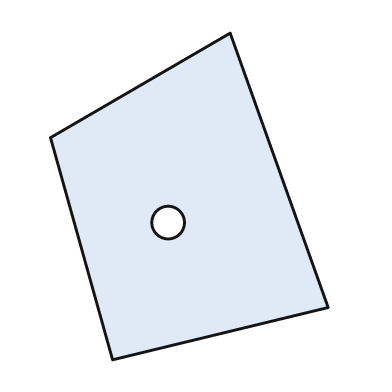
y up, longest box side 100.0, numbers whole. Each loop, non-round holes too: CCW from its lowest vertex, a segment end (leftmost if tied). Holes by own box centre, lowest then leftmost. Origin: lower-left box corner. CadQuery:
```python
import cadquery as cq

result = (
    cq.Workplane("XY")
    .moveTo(19.0, 0.0)
    .lineTo(85.0, 16.0)
    .lineTo(55.0, 100.0)
    .lineTo(0.0, 68.0)
    .close()
    .moveTo(36.0, 42.0)
    .circle(5.0)
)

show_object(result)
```